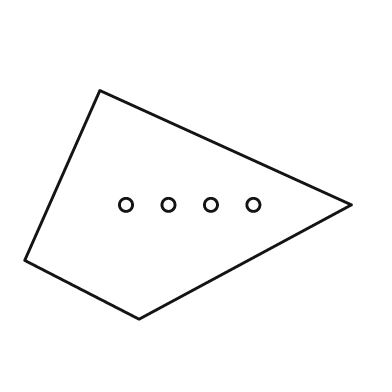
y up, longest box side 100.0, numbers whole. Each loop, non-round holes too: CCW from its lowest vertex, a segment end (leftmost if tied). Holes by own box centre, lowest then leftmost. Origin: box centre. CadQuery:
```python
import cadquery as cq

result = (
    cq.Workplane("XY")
    .moveTo(-15.0, -35.0)
    .lineTo(50.0, 0.0)
    .lineTo(-27.0, 35.0)
    .lineTo(-50.0, -17.0)
    .close()
    .moveTo(-19.0, 0.0)
    .circle(2.0)
    .moveTo(-6.0, 0.0)
    .circle(2.0)
    .moveTo(7.0, 0.0)
    .circle(2.0)
    .moveTo(20.0, 0.0)
    .circle(2.0)
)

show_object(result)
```